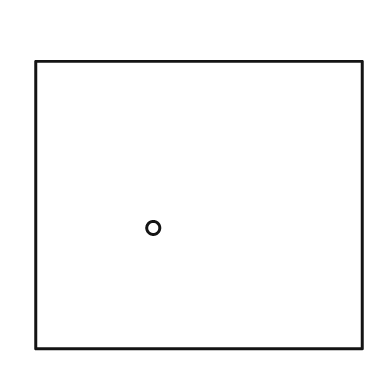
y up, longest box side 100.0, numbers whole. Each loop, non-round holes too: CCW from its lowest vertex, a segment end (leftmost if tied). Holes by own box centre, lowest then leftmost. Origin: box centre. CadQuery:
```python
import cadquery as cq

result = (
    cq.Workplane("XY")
    .moveTo(-50.0, -44.0)
    .lineTo(50.0, -44.0)
    .lineTo(50.0, 44.0)
    .lineTo(-50.0, 44.0)
    .close()
    .moveTo(-14.0, -7.0)
    .circle(2.0)
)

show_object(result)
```